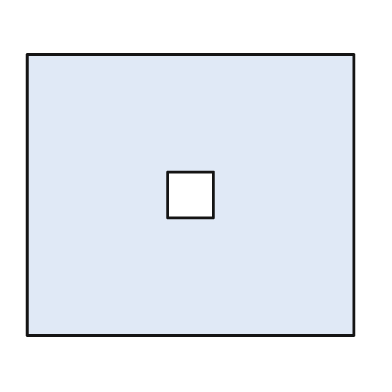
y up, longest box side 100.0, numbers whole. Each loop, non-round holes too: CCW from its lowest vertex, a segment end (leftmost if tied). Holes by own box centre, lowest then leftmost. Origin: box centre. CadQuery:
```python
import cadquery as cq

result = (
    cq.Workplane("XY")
    .moveTo(-50.0, -43.0)
    .lineTo(50.0, -43.0)
    .lineTo(50.0, 43.0)
    .lineTo(-50.0, 43.0)
    .close()
    .moveTo(-7.0, -7.0)
    .lineTo(7.0, -7.0)
    .lineTo(7.0, 7.0)
    .lineTo(-7.0, 7.0)
    .close()
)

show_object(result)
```